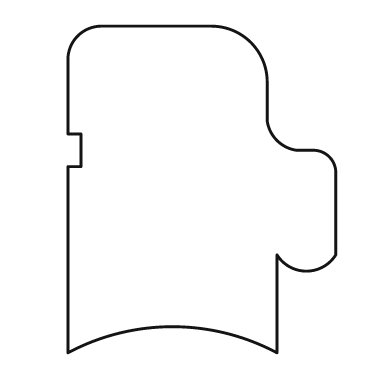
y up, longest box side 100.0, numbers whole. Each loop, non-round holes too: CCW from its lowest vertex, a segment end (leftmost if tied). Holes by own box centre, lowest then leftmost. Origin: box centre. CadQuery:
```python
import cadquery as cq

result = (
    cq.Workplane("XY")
    .moveTo(-41.0, -50.0)
    .threePointArc((-9.0, -42.0), (23.0, -50.0))
    .lineTo(23.0, -20.0)
    .threePointArc((32.0, -25.0), (41.0, -20.0))
    .lineTo(41.0, 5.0)
    .threePointArc((39.0, 10.0), (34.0, 12.0))
    .lineTo(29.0, 12.0)
    .threePointArc((23.0, 15.0), (20.0, 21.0))
    .lineTo(20.0, 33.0)
    .threePointArc((15.0, 45.0), (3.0, 50.0))
    .lineTo(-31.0, 50.0)
    .threePointArc((-38.0, 47.0), (-41.0, 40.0))
    .lineTo(-41.0, 17.0)
    .lineTo(-37.0, 17.0)
    .lineTo(-37.0, 7.0)
    .lineTo(-41.0, 7.0)
    .close()
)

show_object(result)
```